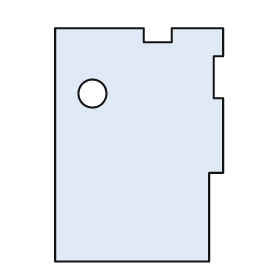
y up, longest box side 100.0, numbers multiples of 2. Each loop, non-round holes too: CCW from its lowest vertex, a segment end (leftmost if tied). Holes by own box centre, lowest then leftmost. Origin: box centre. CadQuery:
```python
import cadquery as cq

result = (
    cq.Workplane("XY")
    .moveTo(-36.0, -50.0)
    .lineTo(30.0, -50.0)
    .lineTo(30.0, -12.0)
    .lineTo(36.0, -12.0)
    .lineTo(36.0, 20.0)
    .lineTo(32.0, 20.0)
    .lineTo(32.0, 38.0)
    .lineTo(36.0, 38.0)
    .lineTo(36.0, 50.0)
    .lineTo(14.0, 50.0)
    .lineTo(14.0, 44.0)
    .lineTo(2.0, 44.0)
    .lineTo(2.0, 50.0)
    .lineTo(-36.0, 50.0)
    .close()
    .moveTo(-20.0, 22.0)
    .circle(6.0)
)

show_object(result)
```